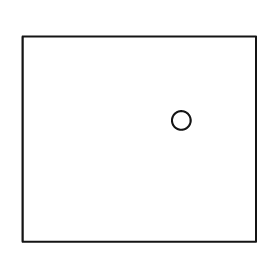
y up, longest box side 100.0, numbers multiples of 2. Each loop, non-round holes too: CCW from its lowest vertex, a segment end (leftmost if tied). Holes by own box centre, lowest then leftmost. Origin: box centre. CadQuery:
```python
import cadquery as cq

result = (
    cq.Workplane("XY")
    .moveTo(-50.0, -44.0)
    .lineTo(50.0, -44.0)
    .lineTo(50.0, 44.0)
    .lineTo(-50.0, 44.0)
    .close()
    .moveTo(18.0, 8.0)
    .circle(4.0)
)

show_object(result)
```